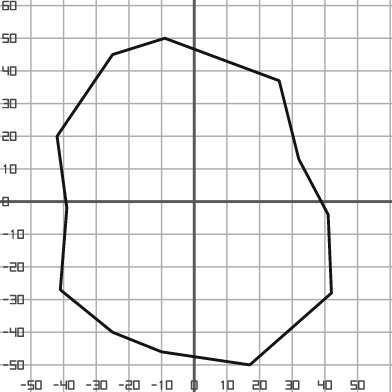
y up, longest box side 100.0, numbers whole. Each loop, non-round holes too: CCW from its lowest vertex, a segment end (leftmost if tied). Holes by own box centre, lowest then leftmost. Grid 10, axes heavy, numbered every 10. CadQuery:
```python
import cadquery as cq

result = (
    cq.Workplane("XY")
    .moveTo(17.0, -50.0)
    .lineTo(42.0, -28.0)
    .lineTo(41.0, -4.0)
    .lineTo(32.0, 13.0)
    .lineTo(26.0, 37.0)
    .lineTo(-9.0, 50.0)
    .lineTo(-25.0, 45.0)
    .lineTo(-42.0, 20.0)
    .lineTo(-39.0, -2.0)
    .lineTo(-41.0, -27.0)
    .lineTo(-25.0, -40.0)
    .lineTo(-10.0, -46.0)
    .close()
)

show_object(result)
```